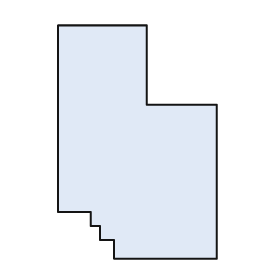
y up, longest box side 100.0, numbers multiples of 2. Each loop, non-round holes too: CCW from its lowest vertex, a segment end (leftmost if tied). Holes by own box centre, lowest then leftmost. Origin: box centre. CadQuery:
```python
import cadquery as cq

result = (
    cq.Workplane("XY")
    .moveTo(-10.0, -50.0)
    .lineTo(34.0, -50.0)
    .lineTo(34.0, 16.0)
    .lineTo(4.0, 16.0)
    .lineTo(4.0, 50.0)
    .lineTo(-34.0, 50.0)
    .lineTo(-34.0, -30.0)
    .lineTo(-20.0, -30.0)
    .lineTo(-20.0, -36.0)
    .lineTo(-16.0, -36.0)
    .lineTo(-16.0, -42.0)
    .lineTo(-10.0, -42.0)
    .close()
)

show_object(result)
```